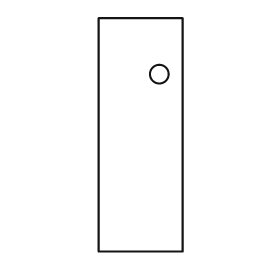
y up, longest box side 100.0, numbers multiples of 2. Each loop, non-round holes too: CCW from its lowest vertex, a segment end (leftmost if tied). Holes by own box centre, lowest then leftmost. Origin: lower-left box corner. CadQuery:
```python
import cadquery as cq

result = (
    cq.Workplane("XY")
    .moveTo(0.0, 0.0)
    .lineTo(36.0, 0.0)
    .lineTo(36.0, 100.0)
    .lineTo(0.0, 100.0)
    .close()
    .moveTo(26.0, 76.0)
    .circle(4.0)
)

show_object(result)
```